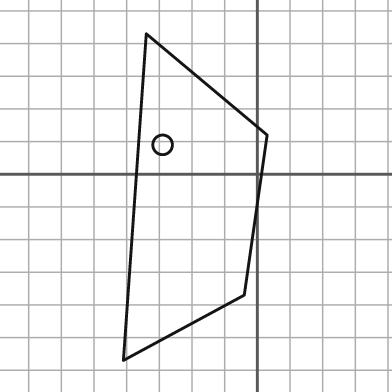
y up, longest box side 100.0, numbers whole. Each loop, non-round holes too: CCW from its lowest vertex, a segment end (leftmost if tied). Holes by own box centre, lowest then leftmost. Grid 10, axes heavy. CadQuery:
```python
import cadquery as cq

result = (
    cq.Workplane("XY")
    .moveTo(-41.0, -57.0)
    .lineTo(-4.0, -37.0)
    .lineTo(3.0, 12.0)
    .lineTo(-34.0, 43.0)
    .close()
    .moveTo(-29.0, 9.0)
    .circle(3.0)
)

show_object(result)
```